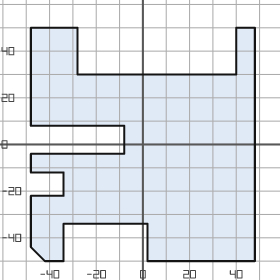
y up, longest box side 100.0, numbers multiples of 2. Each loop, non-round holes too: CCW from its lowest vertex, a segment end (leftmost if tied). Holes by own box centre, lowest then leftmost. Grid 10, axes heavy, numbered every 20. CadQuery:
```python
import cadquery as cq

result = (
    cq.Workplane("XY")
    .moveTo(-42.0, -50.0)
    .lineTo(-34.0, -50.0)
    .lineTo(-34.0, -34.0)
    .lineTo(2.0, -34.0)
    .lineTo(2.0, -50.0)
    .lineTo(48.0, -50.0)
    .lineTo(48.0, 50.0)
    .lineTo(40.0, 50.0)
    .lineTo(40.0, 30.0)
    .lineTo(-28.0, 30.0)
    .lineTo(-28.0, 50.0)
    .lineTo(-48.0, 50.0)
    .lineTo(-48.0, 8.0)
    .lineTo(-8.0, 8.0)
    .lineTo(-8.0, -4.0)
    .lineTo(-48.0, -4.0)
    .lineTo(-48.0, -12.0)
    .lineTo(-34.0, -12.0)
    .lineTo(-34.0, -22.0)
    .lineTo(-48.0, -22.0)
    .lineTo(-48.0, -44.0)
    .close()
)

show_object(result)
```